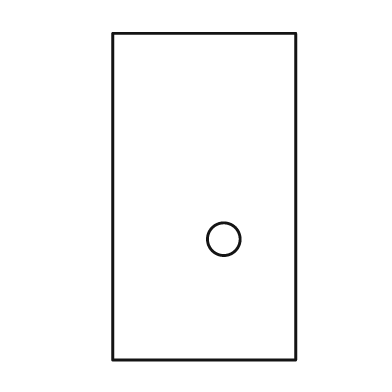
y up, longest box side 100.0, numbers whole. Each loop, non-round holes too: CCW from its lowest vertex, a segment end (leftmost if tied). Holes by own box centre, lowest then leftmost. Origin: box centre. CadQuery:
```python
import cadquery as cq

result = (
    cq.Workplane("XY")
    .moveTo(-28.0, -50.0)
    .lineTo(28.0, -50.0)
    .lineTo(28.0, 50.0)
    .lineTo(-28.0, 50.0)
    .close()
    .moveTo(6.0, -13.0)
    .circle(5.0)
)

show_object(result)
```